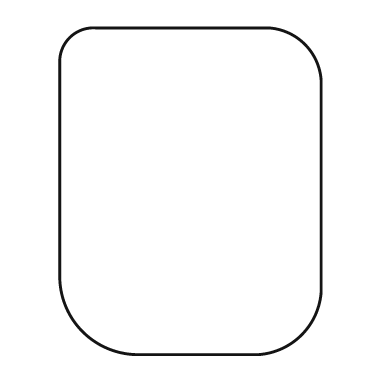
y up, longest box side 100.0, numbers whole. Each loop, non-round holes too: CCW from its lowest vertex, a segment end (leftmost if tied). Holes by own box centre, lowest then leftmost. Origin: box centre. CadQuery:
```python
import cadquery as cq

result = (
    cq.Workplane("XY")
    .moveTo(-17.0, -50.0)
    .lineTo(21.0, -50.0)
    .threePointArc((34.0, -44.0), (40.0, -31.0))
    .lineTo(40.0, 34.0)
    .threePointArc((35.0, 45.0), (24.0, 50.0))
    .lineTo(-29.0, 50.0)
    .threePointArc((-37.0, 47.0), (-40.0, 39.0))
    .lineTo(-40.0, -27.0)
    .threePointArc((-33.0, -43.0), (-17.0, -50.0))
    .close()
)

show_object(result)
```